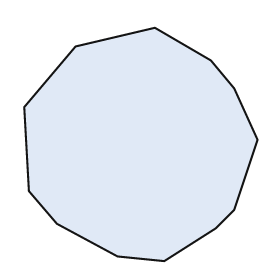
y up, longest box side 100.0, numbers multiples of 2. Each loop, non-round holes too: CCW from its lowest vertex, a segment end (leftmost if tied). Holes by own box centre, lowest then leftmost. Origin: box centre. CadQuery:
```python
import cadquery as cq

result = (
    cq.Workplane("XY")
    .moveTo(10.0, -50.0)
    .lineTo(32.0, -36.0)
    .lineTo(40.0, -28.0)
    .lineTo(50.0, 2.0)
    .lineTo(40.0, 24.0)
    .lineTo(30.0, 36.0)
    .lineTo(6.0, 50.0)
    .lineTo(-28.0, 42.0)
    .lineTo(-50.0, 16.0)
    .lineTo(-48.0, -20.0)
    .lineTo(-36.0, -34.0)
    .lineTo(-10.0, -48.0)
    .close()
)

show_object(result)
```